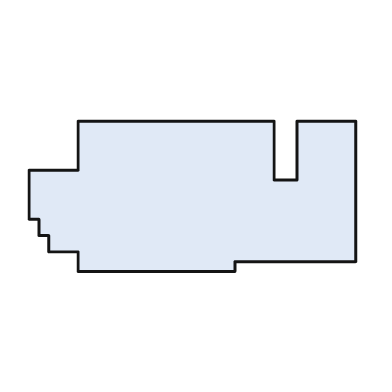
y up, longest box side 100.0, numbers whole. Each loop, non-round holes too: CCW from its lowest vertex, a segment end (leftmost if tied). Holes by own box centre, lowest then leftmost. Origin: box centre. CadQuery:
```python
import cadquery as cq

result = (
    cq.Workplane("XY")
    .moveTo(-35.0, -23.0)
    .lineTo(13.0, -23.0)
    .lineTo(13.0, -20.0)
    .lineTo(50.0, -20.0)
    .lineTo(50.0, 23.0)
    .lineTo(32.0, 23.0)
    .lineTo(32.0, 5.0)
    .lineTo(25.0, 5.0)
    .lineTo(25.0, 23.0)
    .lineTo(-35.0, 23.0)
    .lineTo(-35.0, 8.0)
    .lineTo(-50.0, 8.0)
    .lineTo(-50.0, -7.0)
    .lineTo(-47.0, -7.0)
    .lineTo(-47.0, -12.0)
    .lineTo(-44.0, -12.0)
    .lineTo(-44.0, -17.0)
    .lineTo(-35.0, -17.0)
    .close()
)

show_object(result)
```